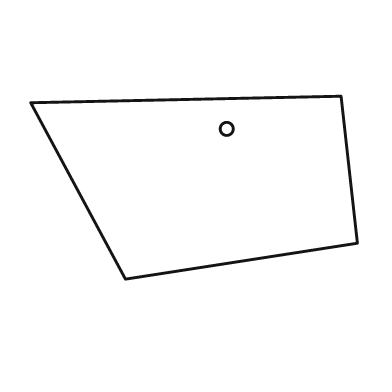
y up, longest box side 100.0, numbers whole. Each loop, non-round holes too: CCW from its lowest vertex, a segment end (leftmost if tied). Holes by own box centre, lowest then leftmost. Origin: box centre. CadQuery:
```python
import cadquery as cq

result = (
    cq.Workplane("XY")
    .moveTo(-21.0, -28.0)
    .lineTo(50.0, -17.0)
    .lineTo(45.0, 28.0)
    .lineTo(-50.0, 26.0)
    .close()
    .moveTo(10.0, 18.0)
    .circle(2.0)
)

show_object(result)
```